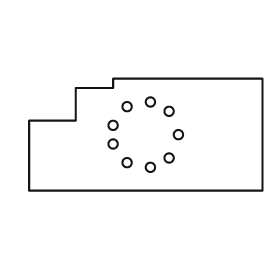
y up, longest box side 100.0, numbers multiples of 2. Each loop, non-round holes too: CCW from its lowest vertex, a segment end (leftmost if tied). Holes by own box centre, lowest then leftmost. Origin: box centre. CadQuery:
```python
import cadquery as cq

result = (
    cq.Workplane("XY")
    .moveTo(-50.0, -24.0)
    .lineTo(50.0, -24.0)
    .lineTo(50.0, 24.0)
    .lineTo(-14.0, 24.0)
    .lineTo(-14.0, 20.0)
    .lineTo(-30.0, 20.0)
    .lineTo(-30.0, 6.0)
    .lineTo(-50.0, 6.0)
    .close()
    .moveTo(2.0, -14.0)
    .circle(2.0)
    .moveTo(-8.0, -12.0)
    .circle(2.0)
    .moveTo(10.0, -10.0)
    .circle(2.0)
    .moveTo(-14.0, -4.0)
    .circle(2.0)
    .moveTo(14.0, 0.0)
    .circle(2.0)
    .moveTo(-14.0, 4.0)
    .circle(2.0)
    .moveTo(10.0, 10.0)
    .circle(2.0)
    .moveTo(-8.0, 12.0)
    .circle(2.0)
    .moveTo(2.0, 14.0)
    .circle(2.0)
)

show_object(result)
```